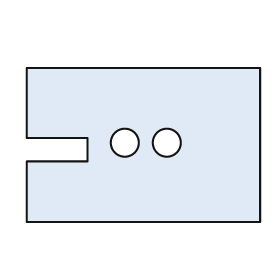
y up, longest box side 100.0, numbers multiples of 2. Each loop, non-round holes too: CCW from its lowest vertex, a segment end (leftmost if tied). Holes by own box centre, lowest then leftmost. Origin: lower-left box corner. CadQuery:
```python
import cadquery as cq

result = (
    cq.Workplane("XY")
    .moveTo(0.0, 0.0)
    .lineTo(100.0, 0.0)
    .lineTo(100.0, 66.0)
    .lineTo(0.0, 66.0)
    .lineTo(0.0, 36.0)
    .lineTo(26.0, 36.0)
    .lineTo(26.0, 26.0)
    .lineTo(0.0, 26.0)
    .close()
    .moveTo(42.0, 34.0)
    .circle(6.0)
    .moveTo(60.0, 34.0)
    .circle(6.0)
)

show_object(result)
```